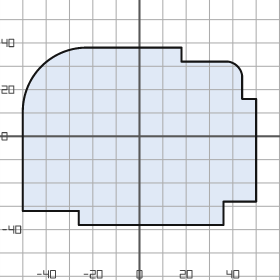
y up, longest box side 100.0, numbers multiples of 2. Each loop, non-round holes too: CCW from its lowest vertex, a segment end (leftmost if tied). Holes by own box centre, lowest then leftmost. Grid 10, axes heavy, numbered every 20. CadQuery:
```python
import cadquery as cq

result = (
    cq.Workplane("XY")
    .moveTo(-26.0, -38.0)
    .lineTo(36.0, -38.0)
    .lineTo(36.0, -28.0)
    .lineTo(50.0, -28.0)
    .lineTo(50.0, 16.0)
    .lineTo(44.0, 16.0)
    .lineTo(44.0, 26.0)
    .threePointArc((42.0, 30.0), (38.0, 32.0))
    .lineTo(18.0, 32.0)
    .lineTo(18.0, 38.0)
    .lineTo(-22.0, 38.0)
    .threePointArc((-42.0, 30.0), (-50.0, 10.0))
    .lineTo(-50.0, -32.0)
    .lineTo(-26.0, -32.0)
    .close()
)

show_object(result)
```